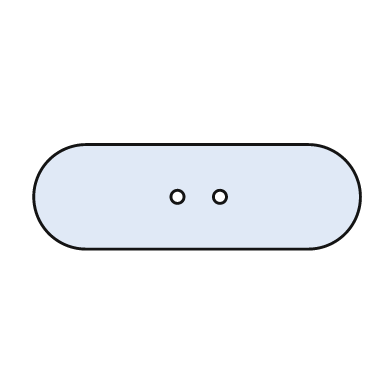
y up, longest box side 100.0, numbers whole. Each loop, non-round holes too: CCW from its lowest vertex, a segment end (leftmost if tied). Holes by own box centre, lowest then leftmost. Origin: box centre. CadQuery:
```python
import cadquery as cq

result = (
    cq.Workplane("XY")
    .moveTo(-34.0, -16.0)
    .lineTo(34.0, -16.0)
    .threePointArc((50.0, 0.0), (34.0, 16.0))
    .lineTo(-34.0, 16.0)
    .threePointArc((-50.0, 0.0), (-34.0, -16.0))
    .close()
    .moveTo(-6.0, 0.0)
    .circle(2.0)
    .moveTo(7.0, 0.0)
    .circle(2.0)
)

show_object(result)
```